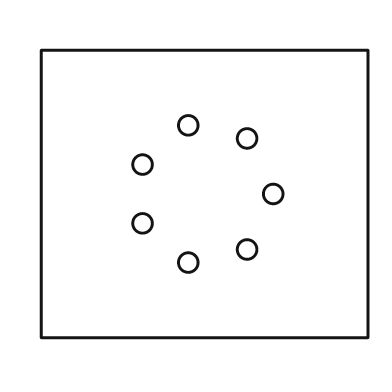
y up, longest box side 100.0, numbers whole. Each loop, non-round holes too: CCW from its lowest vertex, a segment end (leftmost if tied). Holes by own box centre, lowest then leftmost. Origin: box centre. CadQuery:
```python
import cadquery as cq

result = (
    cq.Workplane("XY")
    .moveTo(-50.0, -44.0)
    .lineTo(50.0, -44.0)
    .lineTo(50.0, 44.0)
    .lineTo(-50.0, 44.0)
    .close()
    .moveTo(-5.0, -21.0)
    .circle(3.0)
    .moveTo(13.0, -17.0)
    .circle(3.0)
    .moveTo(-19.0, -9.0)
    .circle(3.0)
    .moveTo(21.0, 0.0)
    .circle(3.0)
    .moveTo(-19.0, 9.0)
    .circle(3.0)
    .moveTo(13.0, 17.0)
    .circle(3.0)
    .moveTo(-5.0, 21.0)
    .circle(3.0)
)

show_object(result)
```